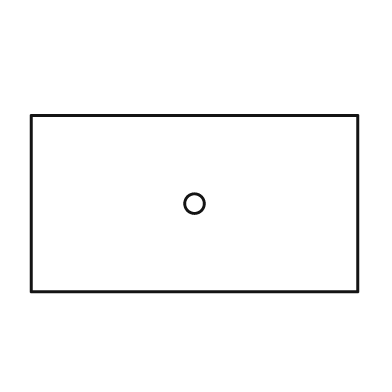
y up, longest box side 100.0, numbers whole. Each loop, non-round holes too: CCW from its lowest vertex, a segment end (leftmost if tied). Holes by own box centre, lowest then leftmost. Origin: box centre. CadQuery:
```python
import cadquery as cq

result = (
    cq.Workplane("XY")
    .moveTo(-50.0, -27.0)
    .lineTo(50.0, -27.0)
    .lineTo(50.0, 27.0)
    .lineTo(-50.0, 27.0)
    .close()
    .moveTo(0.0, 0.0)
    .circle(3.0)
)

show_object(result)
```